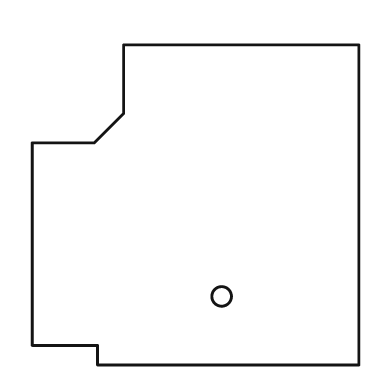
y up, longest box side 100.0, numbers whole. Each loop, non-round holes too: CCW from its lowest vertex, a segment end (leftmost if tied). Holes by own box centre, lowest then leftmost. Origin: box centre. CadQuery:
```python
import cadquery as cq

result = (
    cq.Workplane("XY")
    .moveTo(-30.0, -49.0)
    .lineTo(50.0, -49.0)
    .lineTo(50.0, 49.0)
    .lineTo(-22.0, 49.0)
    .lineTo(-22.0, 28.0)
    .lineTo(-31.0, 19.0)
    .lineTo(-50.0, 19.0)
    .lineTo(-50.0, -43.0)
    .lineTo(-30.0, -43.0)
    .close()
    .moveTo(8.0, -28.0)
    .circle(3.0)
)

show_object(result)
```